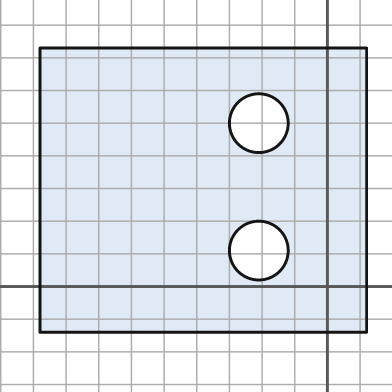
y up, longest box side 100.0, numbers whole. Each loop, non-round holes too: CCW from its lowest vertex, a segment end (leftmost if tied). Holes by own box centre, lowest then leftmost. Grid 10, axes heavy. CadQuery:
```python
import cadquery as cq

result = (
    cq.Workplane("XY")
    .moveTo(-88.0, -14.0)
    .lineTo(12.0, -14.0)
    .lineTo(12.0, 73.0)
    .lineTo(-88.0, 73.0)
    .close()
    .moveTo(-21.0, 11.0)
    .circle(9.0)
    .moveTo(-21.0, 50.0)
    .circle(9.0)
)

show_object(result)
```